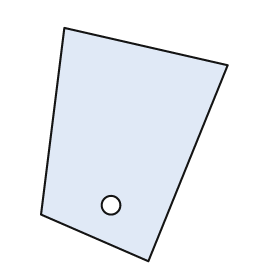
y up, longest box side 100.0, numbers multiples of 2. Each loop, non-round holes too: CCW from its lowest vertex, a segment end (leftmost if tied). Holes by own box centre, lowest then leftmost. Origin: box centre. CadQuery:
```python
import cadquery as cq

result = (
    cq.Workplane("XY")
    .moveTo(6.0, -50.0)
    .lineTo(40.0, 34.0)
    .lineTo(-30.0, 50.0)
    .lineTo(-40.0, -30.0)
    .close()
    .moveTo(-10.0, -26.0)
    .circle(4.0)
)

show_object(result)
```